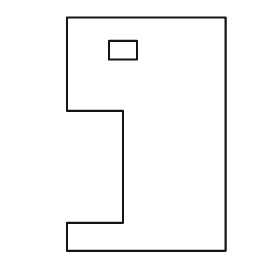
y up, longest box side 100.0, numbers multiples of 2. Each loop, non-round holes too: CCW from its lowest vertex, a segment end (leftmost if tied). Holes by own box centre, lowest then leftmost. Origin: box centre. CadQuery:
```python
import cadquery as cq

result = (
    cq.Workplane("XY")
    .moveTo(-34.0, -50.0)
    .lineTo(34.0, -50.0)
    .lineTo(34.0, 50.0)
    .lineTo(-34.0, 50.0)
    .lineTo(-34.0, 10.0)
    .lineTo(-10.0, 10.0)
    .lineTo(-10.0, -38.0)
    .lineTo(-34.0, -38.0)
    .close()
    .moveTo(-16.0, 32.0)
    .lineTo(-4.0, 32.0)
    .lineTo(-4.0, 40.0)
    .lineTo(-16.0, 40.0)
    .close()
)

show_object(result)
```